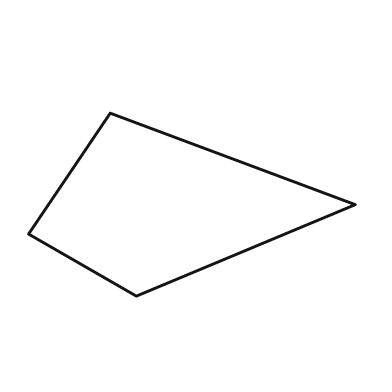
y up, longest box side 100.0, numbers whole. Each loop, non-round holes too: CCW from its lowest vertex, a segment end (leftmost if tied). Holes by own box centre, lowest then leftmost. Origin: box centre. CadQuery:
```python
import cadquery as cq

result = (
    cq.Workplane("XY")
    .moveTo(-17.0, -28.0)
    .lineTo(50.0, 0.0)
    .lineTo(-25.0, 28.0)
    .lineTo(-50.0, -9.0)
    .close()
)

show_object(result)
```